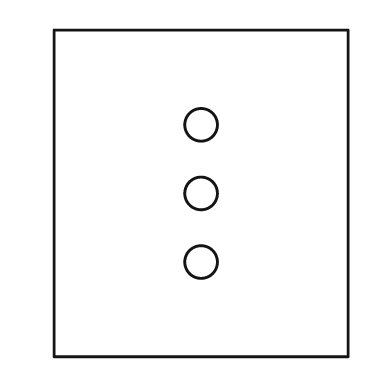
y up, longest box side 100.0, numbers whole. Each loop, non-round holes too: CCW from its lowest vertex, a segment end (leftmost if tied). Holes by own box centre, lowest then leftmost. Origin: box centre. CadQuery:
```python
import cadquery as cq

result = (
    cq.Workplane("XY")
    .moveTo(-45.0, -50.0)
    .lineTo(45.0, -50.0)
    .lineTo(45.0, 50.0)
    .lineTo(-45.0, 50.0)
    .close()
    .moveTo(0.0, -21.0)
    .circle(5.0)
    .moveTo(0.0, 0.0)
    .circle(5.0)
    .moveTo(0.0, 21.0)
    .circle(5.0)
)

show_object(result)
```